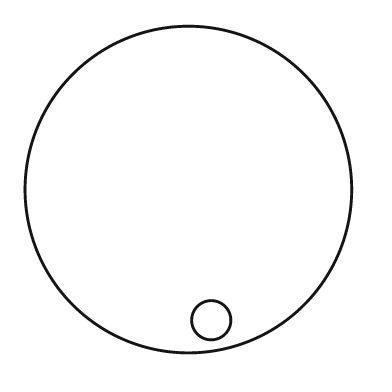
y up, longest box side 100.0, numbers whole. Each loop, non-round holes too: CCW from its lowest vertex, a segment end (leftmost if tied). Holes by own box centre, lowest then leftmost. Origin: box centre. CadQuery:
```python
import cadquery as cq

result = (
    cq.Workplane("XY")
    .moveTo(0.0, 0.0)
    .circle(50.0)
    .moveTo(7.0, -40.0)
    .circle(6.0)
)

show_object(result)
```